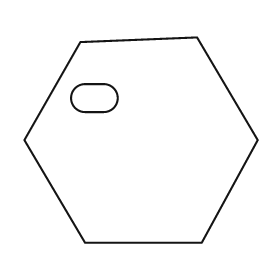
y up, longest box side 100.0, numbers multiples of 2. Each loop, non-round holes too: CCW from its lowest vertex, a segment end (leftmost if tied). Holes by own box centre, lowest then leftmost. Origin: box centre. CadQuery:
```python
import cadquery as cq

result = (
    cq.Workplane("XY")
    .moveTo(-24.0, -44.0)
    .lineTo(26.0, -44.0)
    .lineTo(50.0, 0.0)
    .lineTo(24.0, 44.0)
    .lineTo(-26.0, 42.0)
    .lineTo(-50.0, 0.0)
    .close()
    .moveTo(-24.0, 12.0)
    .lineTo(-16.0, 12.0)
    .threePointArc((-10.0, 18.0), (-16.0, 24.0))
    .lineTo(-24.0, 24.0)
    .threePointArc((-30.0, 18.0), (-24.0, 12.0))
    .close()
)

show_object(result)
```